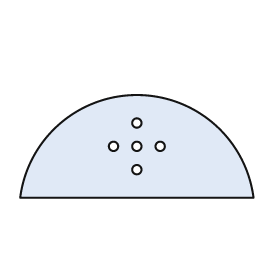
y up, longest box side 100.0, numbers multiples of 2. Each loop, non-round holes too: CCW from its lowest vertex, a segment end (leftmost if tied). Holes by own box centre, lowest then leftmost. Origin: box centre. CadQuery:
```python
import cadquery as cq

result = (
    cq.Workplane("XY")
    .moveTo(-50.0, -22.0)
    .lineTo(50.0, -22.0)
    .threePointArc((0.0, 22.0), (-50.0, -22.0))
    .close()
    .moveTo(0.0, -10.0)
    .circle(2.0)
    .moveTo(-10.0, 0.0)
    .circle(2.0)
    .moveTo(0.0, 0.0)
    .circle(2.0)
    .moveTo(10.0, 0.0)
    .circle(2.0)
    .moveTo(0.0, 10.0)
    .circle(2.0)
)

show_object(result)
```